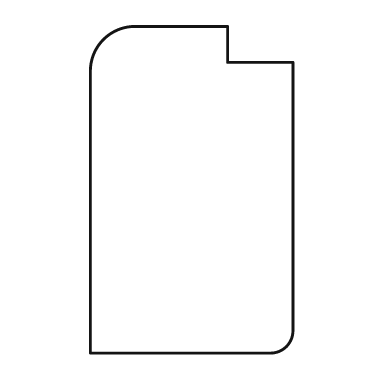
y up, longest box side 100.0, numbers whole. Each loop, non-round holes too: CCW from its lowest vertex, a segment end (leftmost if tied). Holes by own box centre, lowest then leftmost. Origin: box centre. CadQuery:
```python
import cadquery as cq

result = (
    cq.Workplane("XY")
    .moveTo(-31.0, -50.0)
    .lineTo(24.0, -50.0)
    .threePointArc((29.0, -48.0), (31.0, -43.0))
    .lineTo(31.0, 39.0)
    .lineTo(11.0, 39.0)
    .lineTo(11.0, 50.0)
    .lineTo(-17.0, 50.0)
    .threePointArc((-27.0, 46.0), (-31.0, 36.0))
    .close()
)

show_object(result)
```